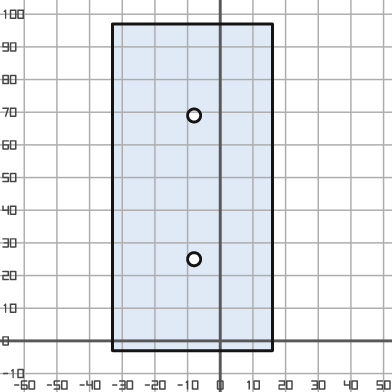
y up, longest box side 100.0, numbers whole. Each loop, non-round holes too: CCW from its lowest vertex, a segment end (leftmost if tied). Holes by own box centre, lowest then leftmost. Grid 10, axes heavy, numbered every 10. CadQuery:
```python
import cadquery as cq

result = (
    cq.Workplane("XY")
    .moveTo(-33.0, -3.0)
    .lineTo(16.0, -3.0)
    .lineTo(16.0, 97.0)
    .lineTo(-33.0, 97.0)
    .close()
    .moveTo(-8.0, 25.0)
    .circle(2.0)
    .moveTo(-8.0, 69.0)
    .circle(2.0)
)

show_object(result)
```